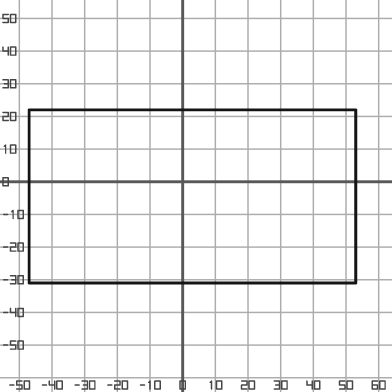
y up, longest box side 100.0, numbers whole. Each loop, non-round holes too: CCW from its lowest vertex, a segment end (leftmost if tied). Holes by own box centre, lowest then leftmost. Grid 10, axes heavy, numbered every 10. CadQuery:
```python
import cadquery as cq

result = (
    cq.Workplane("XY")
    .moveTo(-47.0, -31.0)
    .lineTo(53.0, -31.0)
    .lineTo(53.0, 22.0)
    .lineTo(-47.0, 22.0)
    .close()
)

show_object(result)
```